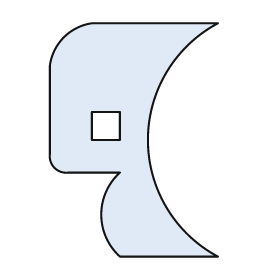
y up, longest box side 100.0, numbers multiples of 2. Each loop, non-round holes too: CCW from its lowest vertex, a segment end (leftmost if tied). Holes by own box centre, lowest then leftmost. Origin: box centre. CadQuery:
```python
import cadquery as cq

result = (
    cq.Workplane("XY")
    .moveTo(-6.0, -50.0)
    .lineTo(36.0, -50.0)
    .threePointArc((6.0, 0.0), (36.0, 50.0))
    .lineTo(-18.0, 50.0)
    .threePointArc((-30.0, 44.0), (-36.0, 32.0))
    .lineTo(-36.0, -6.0)
    .threePointArc((-34.0, -12.0), (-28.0, -14.0))
    .lineTo(-6.0, -14.0)
    .threePointArc((-14.0, -32.0), (-6.0, -50.0))
    .close()
    .moveTo(-18.0, 0.0)
    .lineTo(-6.0, 0.0)
    .lineTo(-6.0, 12.0)
    .lineTo(-18.0, 12.0)
    .close()
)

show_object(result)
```